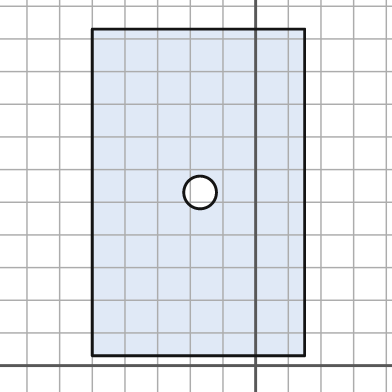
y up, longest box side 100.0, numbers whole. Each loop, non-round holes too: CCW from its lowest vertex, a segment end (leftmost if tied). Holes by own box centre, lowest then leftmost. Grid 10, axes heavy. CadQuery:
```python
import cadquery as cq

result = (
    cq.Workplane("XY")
    .moveTo(-50.0, 3.0)
    .lineTo(15.0, 3.0)
    .lineTo(15.0, 103.0)
    .lineTo(-50.0, 103.0)
    .close()
    .moveTo(-17.0, 53.0)
    .circle(5.0)
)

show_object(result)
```